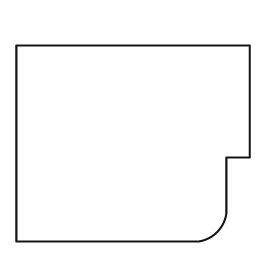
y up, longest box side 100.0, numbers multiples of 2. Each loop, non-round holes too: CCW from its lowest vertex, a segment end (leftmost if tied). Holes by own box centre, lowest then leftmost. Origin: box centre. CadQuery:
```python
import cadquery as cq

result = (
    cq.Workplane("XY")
    .moveTo(-50.0, -42.0)
    .lineTo(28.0, -42.0)
    .threePointArc((36.0, -38.0), (40.0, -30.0))
    .lineTo(40.0, -6.0)
    .lineTo(50.0, -6.0)
    .lineTo(50.0, 42.0)
    .lineTo(-50.0, 42.0)
    .close()
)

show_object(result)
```